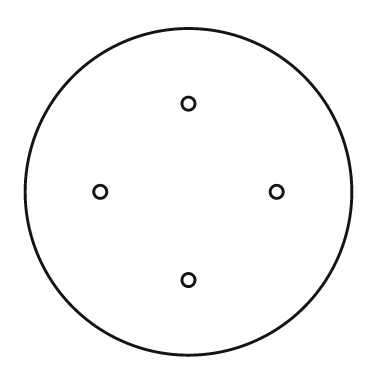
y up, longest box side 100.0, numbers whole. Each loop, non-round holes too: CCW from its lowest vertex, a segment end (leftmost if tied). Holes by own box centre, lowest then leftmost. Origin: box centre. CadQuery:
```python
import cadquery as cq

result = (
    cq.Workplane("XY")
    .moveTo(0.0, 0.0)
    .circle(50.0)
    .moveTo(0.0, -27.0)
    .circle(2.0)
    .moveTo(-27.0, 0.0)
    .circle(2.0)
    .moveTo(27.0, 0.0)
    .circle(2.0)
    .moveTo(0.0, 27.0)
    .circle(2.0)
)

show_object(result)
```